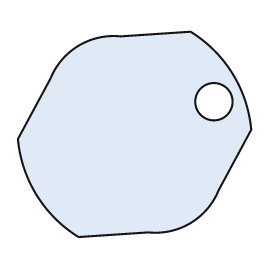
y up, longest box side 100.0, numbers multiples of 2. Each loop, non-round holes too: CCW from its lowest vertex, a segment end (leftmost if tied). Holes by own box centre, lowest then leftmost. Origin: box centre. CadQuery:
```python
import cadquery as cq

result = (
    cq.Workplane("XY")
    .moveTo(-24.0, -44.0)
    .lineTo(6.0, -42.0)
    .threePointArc((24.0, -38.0), (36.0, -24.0))
    .lineTo(50.0, 2.0)
    .threePointArc((42.0, 26.0), (24.0, 44.0))
    .lineTo(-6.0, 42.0)
    .threePointArc((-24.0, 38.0), (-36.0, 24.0))
    .lineTo(-50.0, -2.0)
    .threePointArc((-42.0, -26.0), (-24.0, -44.0))
    .close()
    .moveTo(34.0, 14.0)
    .circle(8.0)
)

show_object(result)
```